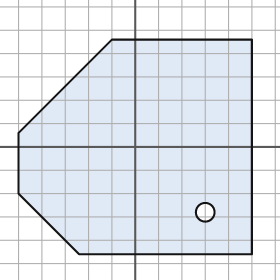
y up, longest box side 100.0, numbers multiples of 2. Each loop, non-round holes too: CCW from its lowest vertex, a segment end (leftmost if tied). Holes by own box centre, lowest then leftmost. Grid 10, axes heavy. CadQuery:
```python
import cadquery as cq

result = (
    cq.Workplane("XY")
    .moveTo(-24.0, -46.0)
    .lineTo(50.0, -46.0)
    .lineTo(50.0, 46.0)
    .lineTo(-10.0, 46.0)
    .lineTo(-50.0, 6.0)
    .lineTo(-50.0, -20.0)
    .close()
    .moveTo(30.0, -28.0)
    .circle(4.0)
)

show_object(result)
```